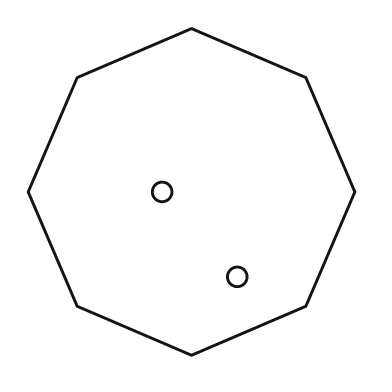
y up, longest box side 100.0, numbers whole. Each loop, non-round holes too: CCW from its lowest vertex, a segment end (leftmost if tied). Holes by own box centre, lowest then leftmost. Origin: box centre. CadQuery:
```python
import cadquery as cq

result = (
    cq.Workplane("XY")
    .moveTo(0.0, -50.0)
    .lineTo(35.0, -35.0)
    .lineTo(50.0, 0.0)
    .lineTo(35.0, 35.0)
    .lineTo(0.0, 50.0)
    .lineTo(-35.0, 35.0)
    .lineTo(-50.0, 0.0)
    .lineTo(-35.0, -35.0)
    .close()
    .moveTo(14.0, -26.0)
    .circle(3.0)
    .moveTo(-9.0, 0.0)
    .circle(3.0)
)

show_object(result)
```